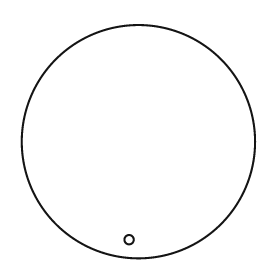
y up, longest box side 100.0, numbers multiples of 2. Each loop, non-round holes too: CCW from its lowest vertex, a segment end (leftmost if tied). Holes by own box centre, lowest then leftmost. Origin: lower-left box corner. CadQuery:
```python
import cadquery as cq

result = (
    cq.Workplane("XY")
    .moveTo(50.0, 50.0)
    .circle(50.0)
    .moveTo(46.0, 8.0)
    .circle(2.0)
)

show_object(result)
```